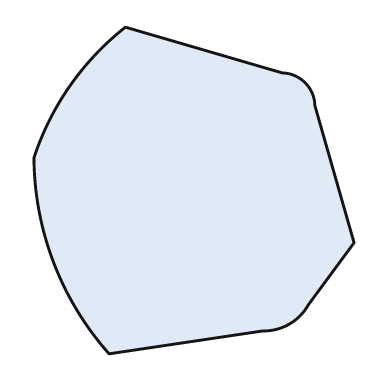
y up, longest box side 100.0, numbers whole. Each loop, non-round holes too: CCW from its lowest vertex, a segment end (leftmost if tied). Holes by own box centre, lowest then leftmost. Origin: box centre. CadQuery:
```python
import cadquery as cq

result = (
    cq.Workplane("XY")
    .moveTo(-26.0, -50.0)
    .lineTo(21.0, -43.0)
    .threePointArc((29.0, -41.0), (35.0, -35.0))
    .lineTo(49.0, -16.0)
    .lineTo(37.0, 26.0)
    .threePointArc((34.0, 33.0), (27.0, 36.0))
    .lineTo(-21.0, 50.0)
    .threePointArc((-38.0, 32.0), (-49.0, 10.0))
    .threePointArc((-43.0, -22.0), (-26.0, -50.0))
    .close()
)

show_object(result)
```